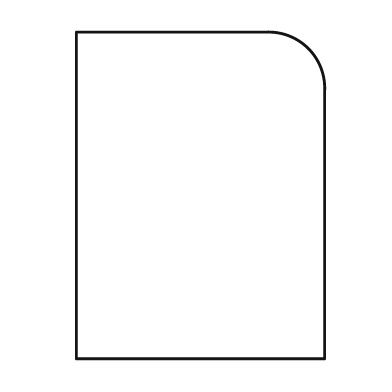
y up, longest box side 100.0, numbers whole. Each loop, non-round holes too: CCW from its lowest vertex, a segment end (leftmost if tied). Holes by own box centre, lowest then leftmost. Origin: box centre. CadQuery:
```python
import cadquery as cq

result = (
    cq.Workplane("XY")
    .moveTo(-38.0, -50.0)
    .lineTo(38.0, -50.0)
    .lineTo(38.0, 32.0)
    .threePointArc((33.0, 45.0), (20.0, 50.0))
    .lineTo(-38.0, 50.0)
    .close()
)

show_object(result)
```